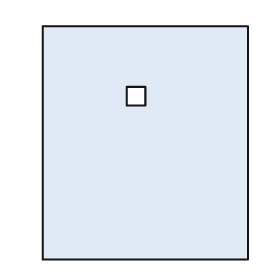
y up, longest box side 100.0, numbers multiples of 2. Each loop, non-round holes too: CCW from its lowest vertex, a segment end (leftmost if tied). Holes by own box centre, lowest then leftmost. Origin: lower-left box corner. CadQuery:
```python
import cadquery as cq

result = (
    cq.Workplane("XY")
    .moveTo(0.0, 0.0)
    .lineTo(88.0, 0.0)
    .lineTo(88.0, 100.0)
    .lineTo(0.0, 100.0)
    .close()
    .moveTo(36.0, 66.0)
    .lineTo(44.0, 66.0)
    .lineTo(44.0, 74.0)
    .lineTo(36.0, 74.0)
    .close()
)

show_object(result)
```